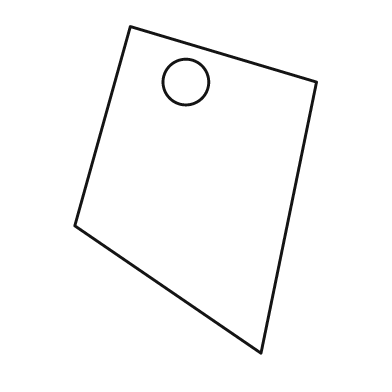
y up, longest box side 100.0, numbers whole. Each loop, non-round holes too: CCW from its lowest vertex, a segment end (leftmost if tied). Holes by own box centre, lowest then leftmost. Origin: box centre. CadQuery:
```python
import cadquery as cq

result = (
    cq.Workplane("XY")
    .moveTo(20.0, -50.0)
    .lineTo(37.0, 33.0)
    .lineTo(-20.0, 50.0)
    .lineTo(-37.0, -11.0)
    .close()
    .moveTo(-3.0, 33.0)
    .circle(7.0)
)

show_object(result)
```